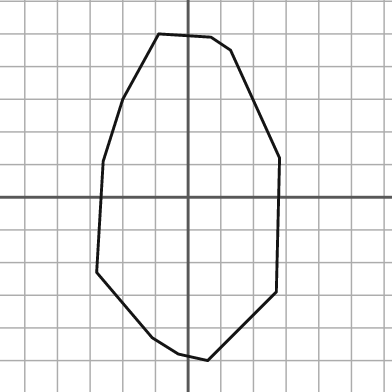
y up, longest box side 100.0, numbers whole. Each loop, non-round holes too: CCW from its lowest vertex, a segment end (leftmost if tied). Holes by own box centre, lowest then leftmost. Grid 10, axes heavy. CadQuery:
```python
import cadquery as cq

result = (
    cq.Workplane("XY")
    .moveTo(6.0, -50.0)
    .lineTo(27.0, -29.0)
    .lineTo(28.0, 12.0)
    .lineTo(13.0, 45.0)
    .lineTo(7.0, 49.0)
    .lineTo(-9.0, 50.0)
    .lineTo(-20.0, 30.0)
    .lineTo(-26.0, 11.0)
    .lineTo(-28.0, -23.0)
    .lineTo(-11.0, -43.0)
    .lineTo(-3.0, -48.0)
    .close()
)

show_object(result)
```